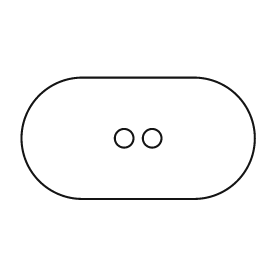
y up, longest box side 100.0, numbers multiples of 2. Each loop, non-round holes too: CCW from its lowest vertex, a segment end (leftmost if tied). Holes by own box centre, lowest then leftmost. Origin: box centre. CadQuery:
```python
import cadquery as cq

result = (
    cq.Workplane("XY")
    .moveTo(-24.0, -26.0)
    .lineTo(24.0, -26.0)
    .threePointArc((50.0, 0.0), (24.0, 26.0))
    .lineTo(-24.0, 26.0)
    .threePointArc((-50.0, 0.0), (-24.0, -26.0))
    .close()
    .moveTo(-6.0, 0.0)
    .circle(4.0)
    .moveTo(6.0, 0.0)
    .circle(4.0)
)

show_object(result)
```